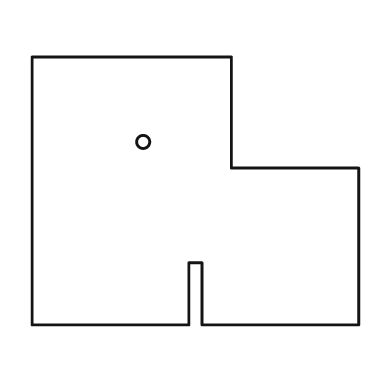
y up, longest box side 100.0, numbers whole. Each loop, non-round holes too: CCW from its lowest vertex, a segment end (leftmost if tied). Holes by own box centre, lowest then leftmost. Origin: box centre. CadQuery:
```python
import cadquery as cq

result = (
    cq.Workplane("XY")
    .moveTo(-50.0, -41.0)
    .lineTo(-2.0, -41.0)
    .lineTo(-2.0, -22.0)
    .lineTo(2.0, -22.0)
    .lineTo(2.0, -41.0)
    .lineTo(50.0, -41.0)
    .lineTo(50.0, 7.0)
    .lineTo(11.0, 7.0)
    .lineTo(11.0, 41.0)
    .lineTo(-50.0, 41.0)
    .close()
    .moveTo(-16.0, 15.0)
    .circle(2.0)
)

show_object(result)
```